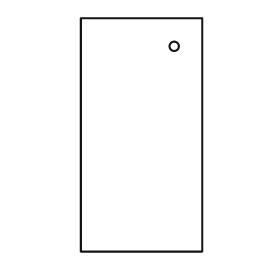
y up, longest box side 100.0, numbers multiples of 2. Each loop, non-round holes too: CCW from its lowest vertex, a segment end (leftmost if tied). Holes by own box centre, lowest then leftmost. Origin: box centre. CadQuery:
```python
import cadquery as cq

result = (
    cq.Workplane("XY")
    .moveTo(-26.0, -50.0)
    .lineTo(26.0, -50.0)
    .lineTo(26.0, 50.0)
    .lineTo(-26.0, 50.0)
    .close()
    .moveTo(14.0, 38.0)
    .circle(2.0)
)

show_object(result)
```